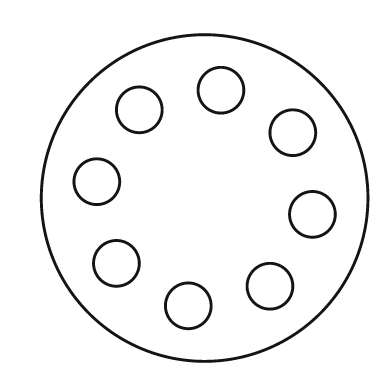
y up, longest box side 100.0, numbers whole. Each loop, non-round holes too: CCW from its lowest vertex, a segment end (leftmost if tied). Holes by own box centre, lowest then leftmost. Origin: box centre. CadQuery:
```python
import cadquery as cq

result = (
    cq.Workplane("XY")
    .moveTo(0.0, 0.0)
    .circle(50.0)
    .moveTo(-5.0, -33.0)
    .circle(7.0)
    .moveTo(20.0, -27.0)
    .circle(7.0)
    .moveTo(-27.0, -20.0)
    .circle(7.0)
    .moveTo(33.0, -5.0)
    .circle(7.0)
    .moveTo(-33.0, 5.0)
    .circle(7.0)
    .moveTo(27.0, 20.0)
    .circle(7.0)
    .moveTo(-20.0, 27.0)
    .circle(7.0)
    .moveTo(5.0, 33.0)
    .circle(7.0)
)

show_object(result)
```